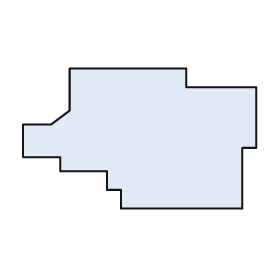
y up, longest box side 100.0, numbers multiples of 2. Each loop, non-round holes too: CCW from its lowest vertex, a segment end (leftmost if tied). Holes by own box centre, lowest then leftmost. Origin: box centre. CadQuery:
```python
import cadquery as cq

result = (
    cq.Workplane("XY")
    .moveTo(-8.0, -30.0)
    .lineTo(44.0, -30.0)
    .lineTo(44.0, -4.0)
    .lineTo(50.0, -4.0)
    .lineTo(50.0, 22.0)
    .lineTo(20.0, 22.0)
    .lineTo(20.0, 30.0)
    .lineTo(-30.0, 30.0)
    .lineTo(-30.0, 12.0)
    .lineTo(-38.0, 6.0)
    .lineTo(-50.0, 6.0)
    .lineTo(-50.0, -8.0)
    .lineTo(-34.0, -8.0)
    .lineTo(-34.0, -14.0)
    .lineTo(-14.0, -14.0)
    .lineTo(-14.0, -22.0)
    .lineTo(-8.0, -22.0)
    .close()
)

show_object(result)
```